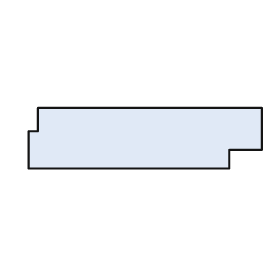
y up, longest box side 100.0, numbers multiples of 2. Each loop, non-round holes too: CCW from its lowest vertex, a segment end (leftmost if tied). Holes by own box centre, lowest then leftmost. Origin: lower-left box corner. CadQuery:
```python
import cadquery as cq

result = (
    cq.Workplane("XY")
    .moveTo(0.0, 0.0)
    .lineTo(86.0, 0.0)
    .lineTo(86.0, 8.0)
    .lineTo(100.0, 8.0)
    .lineTo(100.0, 26.0)
    .lineTo(4.0, 26.0)
    .lineTo(4.0, 16.0)
    .lineTo(0.0, 16.0)
    .close()
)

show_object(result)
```